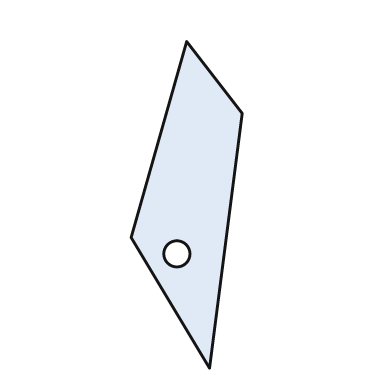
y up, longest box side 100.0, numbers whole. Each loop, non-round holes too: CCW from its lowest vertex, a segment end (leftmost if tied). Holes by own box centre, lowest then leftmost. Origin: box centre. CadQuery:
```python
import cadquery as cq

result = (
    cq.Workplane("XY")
    .moveTo(7.0, -50.0)
    .lineTo(17.0, 28.0)
    .lineTo(0.0, 50.0)
    .lineTo(-17.0, -10.0)
    .close()
    .moveTo(-3.0, -15.0)
    .circle(4.0)
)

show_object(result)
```